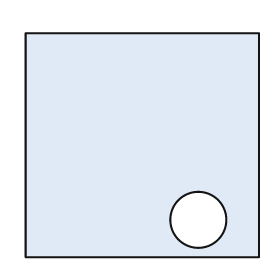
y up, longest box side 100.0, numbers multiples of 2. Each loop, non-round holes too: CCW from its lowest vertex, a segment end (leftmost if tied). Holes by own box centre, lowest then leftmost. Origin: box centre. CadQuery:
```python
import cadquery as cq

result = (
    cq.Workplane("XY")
    .moveTo(-50.0, -48.0)
    .lineTo(50.0, -48.0)
    .lineTo(50.0, 48.0)
    .lineTo(-50.0, 48.0)
    .close()
    .moveTo(24.0, -32.0)
    .circle(12.0)
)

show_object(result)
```